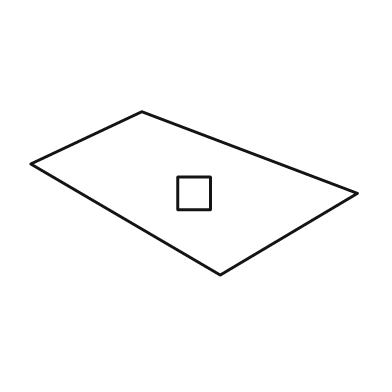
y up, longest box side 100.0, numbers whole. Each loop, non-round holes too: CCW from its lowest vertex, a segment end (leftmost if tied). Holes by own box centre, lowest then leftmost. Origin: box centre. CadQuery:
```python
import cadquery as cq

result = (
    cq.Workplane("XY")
    .moveTo(8.0, -25.0)
    .lineTo(50.0, 0.0)
    .lineTo(-16.0, 25.0)
    .lineTo(-50.0, 9.0)
    .close()
    .moveTo(-5.0, -5.0)
    .lineTo(5.0, -5.0)
    .lineTo(5.0, 5.0)
    .lineTo(-5.0, 5.0)
    .close()
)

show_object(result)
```